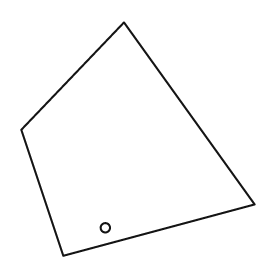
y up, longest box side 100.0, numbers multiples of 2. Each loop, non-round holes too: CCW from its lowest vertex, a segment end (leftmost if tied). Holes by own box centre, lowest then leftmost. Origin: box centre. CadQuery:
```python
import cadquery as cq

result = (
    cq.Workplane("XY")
    .moveTo(-32.0, -50.0)
    .lineTo(50.0, -28.0)
    .lineTo(-6.0, 50.0)
    .lineTo(-50.0, 4.0)
    .close()
    .moveTo(-14.0, -38.0)
    .circle(2.0)
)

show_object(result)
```